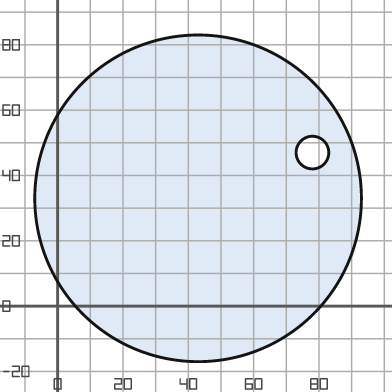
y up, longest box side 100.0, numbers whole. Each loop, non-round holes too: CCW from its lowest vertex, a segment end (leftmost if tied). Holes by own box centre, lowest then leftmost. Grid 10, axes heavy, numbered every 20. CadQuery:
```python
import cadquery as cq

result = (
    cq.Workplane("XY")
    .moveTo(43.0, 33.0)
    .circle(50.0)
    .moveTo(78.0, 47.0)
    .circle(5.0)
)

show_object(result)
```